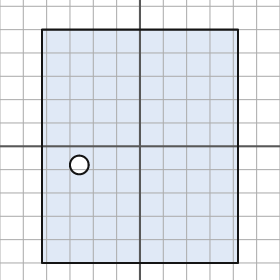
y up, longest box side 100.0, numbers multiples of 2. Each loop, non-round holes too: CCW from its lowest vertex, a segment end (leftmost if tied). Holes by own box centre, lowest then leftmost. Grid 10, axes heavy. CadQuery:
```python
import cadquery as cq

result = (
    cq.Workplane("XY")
    .moveTo(-42.0, -50.0)
    .lineTo(42.0, -50.0)
    .lineTo(42.0, 50.0)
    .lineTo(-42.0, 50.0)
    .close()
    .moveTo(-26.0, -8.0)
    .circle(4.0)
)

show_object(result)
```